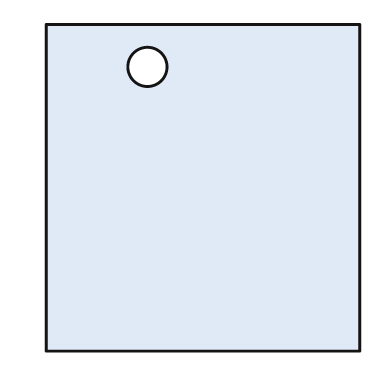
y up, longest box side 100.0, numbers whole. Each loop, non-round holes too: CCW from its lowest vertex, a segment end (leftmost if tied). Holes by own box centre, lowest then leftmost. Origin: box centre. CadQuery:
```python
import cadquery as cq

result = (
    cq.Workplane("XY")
    .moveTo(-48.0, -50.0)
    .lineTo(48.0, -50.0)
    .lineTo(48.0, 50.0)
    .lineTo(-48.0, 50.0)
    .close()
    .moveTo(-17.0, 37.0)
    .circle(6.0)
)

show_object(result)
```